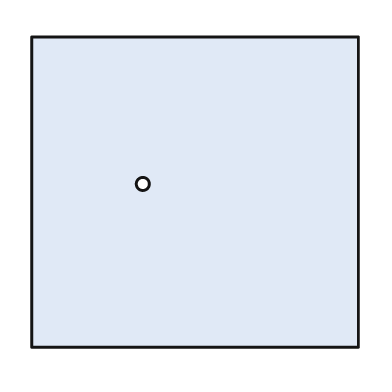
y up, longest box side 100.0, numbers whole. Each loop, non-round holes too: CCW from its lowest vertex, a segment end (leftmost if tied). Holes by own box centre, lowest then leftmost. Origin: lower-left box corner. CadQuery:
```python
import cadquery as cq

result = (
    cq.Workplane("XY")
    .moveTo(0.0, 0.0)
    .lineTo(100.0, 0.0)
    .lineTo(100.0, 95.0)
    .lineTo(0.0, 95.0)
    .close()
    .moveTo(34.0, 50.0)
    .circle(2.0)
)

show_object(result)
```